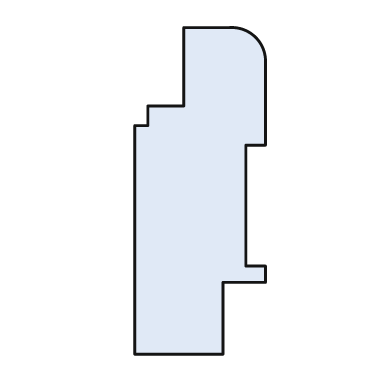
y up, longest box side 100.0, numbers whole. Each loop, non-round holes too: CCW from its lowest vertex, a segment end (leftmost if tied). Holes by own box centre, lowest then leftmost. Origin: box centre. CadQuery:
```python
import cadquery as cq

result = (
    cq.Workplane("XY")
    .moveTo(-20.0, -50.0)
    .lineTo(7.0, -50.0)
    .lineTo(7.0, -28.0)
    .lineTo(20.0, -28.0)
    .lineTo(20.0, -23.0)
    .lineTo(14.0, -23.0)
    .lineTo(14.0, 14.0)
    .lineTo(20.0, 14.0)
    .lineTo(20.0, 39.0)
    .threePointArc((17.0, 47.0), (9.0, 50.0))
    .lineTo(-5.0, 50.0)
    .lineTo(-5.0, 26.0)
    .lineTo(-16.0, 26.0)
    .lineTo(-16.0, 20.0)
    .lineTo(-20.0, 20.0)
    .close()
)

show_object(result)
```